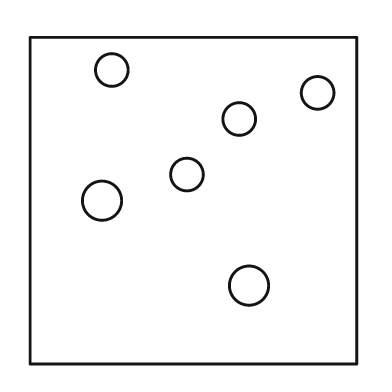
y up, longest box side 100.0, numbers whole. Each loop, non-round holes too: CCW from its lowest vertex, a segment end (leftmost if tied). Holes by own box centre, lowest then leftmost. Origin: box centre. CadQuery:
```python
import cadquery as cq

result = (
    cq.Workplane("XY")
    .moveTo(-50.0, -50.0)
    .lineTo(50.0, -50.0)
    .lineTo(50.0, 50.0)
    .lineTo(-50.0, 50.0)
    .close()
    .moveTo(17.0, -26.0)
    .circle(6.0)
    .moveTo(-28.0, 0.0)
    .circle(6.0)
    .moveTo(-2.0, 8.0)
    .circle(5.0)
    .moveTo(14.0, 25.0)
    .circle(5.0)
    .moveTo(38.0, 33.0)
    .circle(5.0)
    .moveTo(-25.0, 40.0)
    .circle(5.0)
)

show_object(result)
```